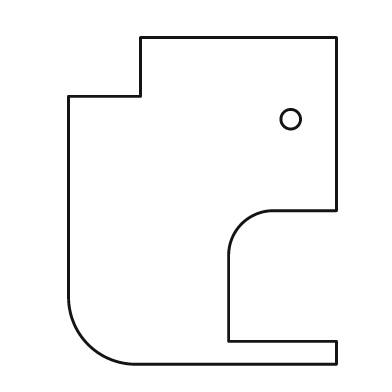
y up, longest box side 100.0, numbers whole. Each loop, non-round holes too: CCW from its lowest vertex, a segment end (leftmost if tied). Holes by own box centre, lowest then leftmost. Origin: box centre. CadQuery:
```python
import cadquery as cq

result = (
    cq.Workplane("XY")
    .moveTo(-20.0, -50.0)
    .lineTo(41.0, -50.0)
    .lineTo(41.0, -43.0)
    .lineTo(8.0, -43.0)
    .lineTo(8.0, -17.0)
    .threePointArc((12.0, -7.0), (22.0, -3.0))
    .lineTo(41.0, -3.0)
    .lineTo(41.0, 50.0)
    .lineTo(-19.0, 50.0)
    .lineTo(-19.0, 32.0)
    .lineTo(-41.0, 32.0)
    .lineTo(-41.0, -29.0)
    .threePointArc((-35.0, -44.0), (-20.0, -50.0))
    .close()
    .moveTo(27.0, 25.0)
    .circle(3.0)
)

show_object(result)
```